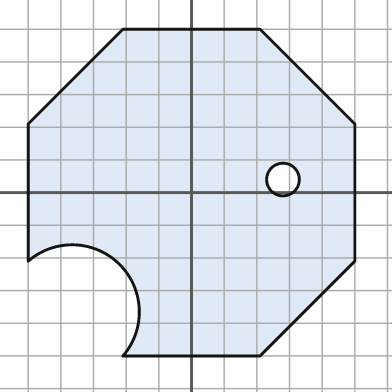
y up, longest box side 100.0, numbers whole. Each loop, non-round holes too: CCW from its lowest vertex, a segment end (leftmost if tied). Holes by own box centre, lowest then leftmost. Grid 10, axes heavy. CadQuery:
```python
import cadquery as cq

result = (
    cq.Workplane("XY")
    .moveTo(-21.0, -50.0)
    .lineTo(21.0, -50.0)
    .lineTo(50.0, -21.0)
    .lineTo(50.0, 21.0)
    .lineTo(21.0, 50.0)
    .lineTo(-21.0, 50.0)
    .lineTo(-50.0, 21.0)
    .lineTo(-50.0, -21.0)
    .threePointArc((-22.0, -22.0), (-21.0, -50.0))
    .close()
    .moveTo(28.0, 4.0)
    .circle(5.0)
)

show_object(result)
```